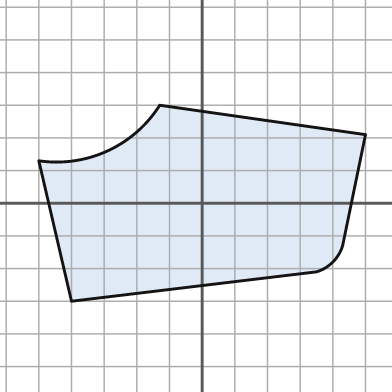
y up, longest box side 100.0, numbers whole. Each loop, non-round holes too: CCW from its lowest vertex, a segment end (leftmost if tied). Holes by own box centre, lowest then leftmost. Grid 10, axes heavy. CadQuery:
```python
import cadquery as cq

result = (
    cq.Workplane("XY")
    .moveTo(-40.0, -30.0)
    .lineTo(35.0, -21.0)
    .threePointArc((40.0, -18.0), (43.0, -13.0))
    .lineTo(50.0, 21.0)
    .lineTo(-13.0, 30.0)
    .threePointArc((-29.0, 16.0), (-50.0, 13.0))
    .close()
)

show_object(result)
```